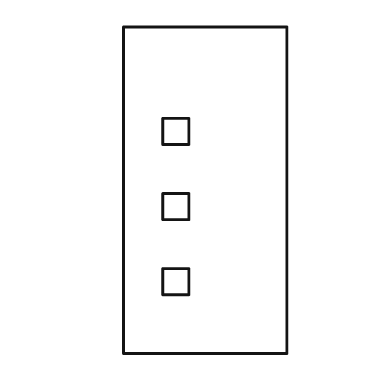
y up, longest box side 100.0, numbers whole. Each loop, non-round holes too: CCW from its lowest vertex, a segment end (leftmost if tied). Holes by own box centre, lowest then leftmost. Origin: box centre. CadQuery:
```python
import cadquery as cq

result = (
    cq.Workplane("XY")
    .moveTo(-25.0, -50.0)
    .lineTo(25.0, -50.0)
    .lineTo(25.0, 50.0)
    .lineTo(-25.0, 50.0)
    .close()
    .moveTo(-13.0, -32.0)
    .lineTo(-5.0, -32.0)
    .lineTo(-5.0, -24.0)
    .lineTo(-13.0, -24.0)
    .close()
    .moveTo(-13.0, -9.0)
    .lineTo(-5.0, -9.0)
    .lineTo(-5.0, -1.0)
    .lineTo(-13.0, -1.0)
    .close()
    .moveTo(-13.0, 14.0)
    .lineTo(-5.0, 14.0)
    .lineTo(-5.0, 22.0)
    .lineTo(-13.0, 22.0)
    .close()
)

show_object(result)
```